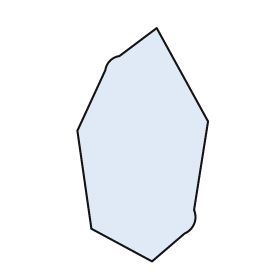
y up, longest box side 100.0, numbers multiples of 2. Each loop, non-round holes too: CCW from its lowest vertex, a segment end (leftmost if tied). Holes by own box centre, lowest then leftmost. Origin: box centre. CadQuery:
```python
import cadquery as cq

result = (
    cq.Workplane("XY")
    .moveTo(4.0, -50.0)
    .lineTo(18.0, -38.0)
    .threePointArc((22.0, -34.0), (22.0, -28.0))
    .lineTo(28.0, 10.0)
    .lineTo(6.0, 50.0)
    .lineTo(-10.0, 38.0)
    .threePointArc((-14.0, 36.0), (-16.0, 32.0))
    .lineTo(-28.0, 6.0)
    .lineTo(-22.0, -36.0)
    .close()
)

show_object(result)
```